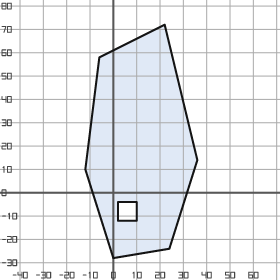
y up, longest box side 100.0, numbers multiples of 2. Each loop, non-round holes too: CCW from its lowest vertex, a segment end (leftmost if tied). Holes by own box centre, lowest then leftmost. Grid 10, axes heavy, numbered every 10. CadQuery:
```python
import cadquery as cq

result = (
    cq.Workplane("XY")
    .moveTo(0.0, -28.0)
    .lineTo(24.0, -24.0)
    .lineTo(36.0, 14.0)
    .lineTo(22.0, 72.0)
    .lineTo(-6.0, 58.0)
    .lineTo(-12.0, 10.0)
    .close()
    .moveTo(2.0, -12.0)
    .lineTo(10.0, -12.0)
    .lineTo(10.0, -4.0)
    .lineTo(2.0, -4.0)
    .close()
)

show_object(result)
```